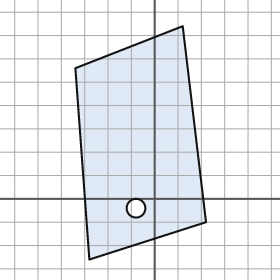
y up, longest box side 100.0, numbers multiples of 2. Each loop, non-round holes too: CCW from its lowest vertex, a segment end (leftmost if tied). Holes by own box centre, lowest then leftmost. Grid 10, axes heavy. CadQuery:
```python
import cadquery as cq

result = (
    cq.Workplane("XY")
    .moveTo(-28.0, -26.0)
    .lineTo(22.0, -10.0)
    .lineTo(12.0, 74.0)
    .lineTo(-34.0, 56.0)
    .close()
    .moveTo(-8.0, -4.0)
    .circle(4.0)
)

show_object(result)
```